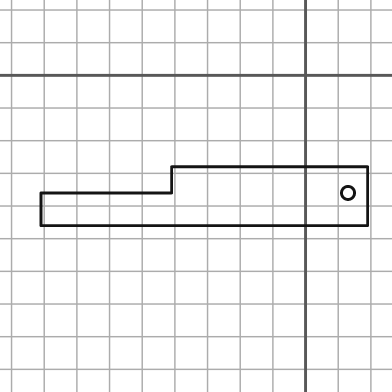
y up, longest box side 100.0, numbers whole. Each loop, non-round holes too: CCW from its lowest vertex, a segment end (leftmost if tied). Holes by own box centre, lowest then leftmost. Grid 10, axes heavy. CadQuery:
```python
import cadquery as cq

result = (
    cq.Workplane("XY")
    .moveTo(-81.0, -46.0)
    .lineTo(19.0, -46.0)
    .lineTo(19.0, -28.0)
    .lineTo(-41.0, -28.0)
    .lineTo(-41.0, -36.0)
    .lineTo(-81.0, -36.0)
    .close()
    .moveTo(13.0, -36.0)
    .circle(2.0)
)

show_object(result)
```